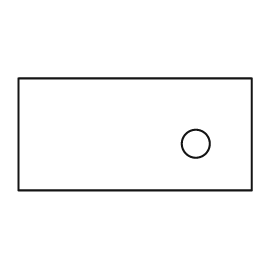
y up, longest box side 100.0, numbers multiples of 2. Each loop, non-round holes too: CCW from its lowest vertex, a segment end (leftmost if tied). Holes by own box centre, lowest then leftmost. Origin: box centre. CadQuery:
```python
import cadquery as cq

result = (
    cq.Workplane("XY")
    .moveTo(-50.0, -24.0)
    .lineTo(50.0, -24.0)
    .lineTo(50.0, 24.0)
    .lineTo(-50.0, 24.0)
    .close()
    .moveTo(26.0, -4.0)
    .circle(6.0)
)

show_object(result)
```